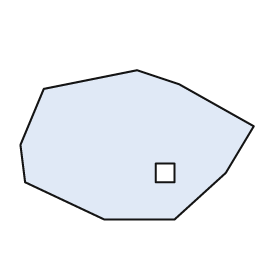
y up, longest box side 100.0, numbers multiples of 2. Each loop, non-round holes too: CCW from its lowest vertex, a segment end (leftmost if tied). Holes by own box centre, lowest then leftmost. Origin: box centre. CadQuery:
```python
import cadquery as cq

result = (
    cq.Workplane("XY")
    .moveTo(-14.0, -32.0)
    .lineTo(16.0, -32.0)
    .lineTo(38.0, -12.0)
    .lineTo(50.0, 8.0)
    .lineTo(18.0, 26.0)
    .lineTo(0.0, 32.0)
    .lineTo(-40.0, 24.0)
    .lineTo(-50.0, 0.0)
    .lineTo(-48.0, -16.0)
    .close()
    .moveTo(8.0, -16.0)
    .lineTo(16.0, -16.0)
    .lineTo(16.0, -8.0)
    .lineTo(8.0, -8.0)
    .close()
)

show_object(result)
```